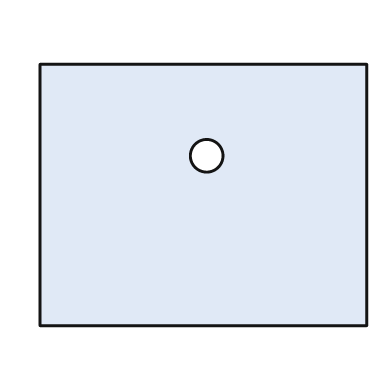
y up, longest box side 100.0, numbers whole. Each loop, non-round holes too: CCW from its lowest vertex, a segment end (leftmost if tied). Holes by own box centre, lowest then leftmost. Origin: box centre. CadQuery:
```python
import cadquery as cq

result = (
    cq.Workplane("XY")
    .moveTo(-50.0, -40.0)
    .lineTo(50.0, -40.0)
    .lineTo(50.0, 40.0)
    .lineTo(-50.0, 40.0)
    .close()
    .moveTo(1.0, 12.0)
    .circle(5.0)
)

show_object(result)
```